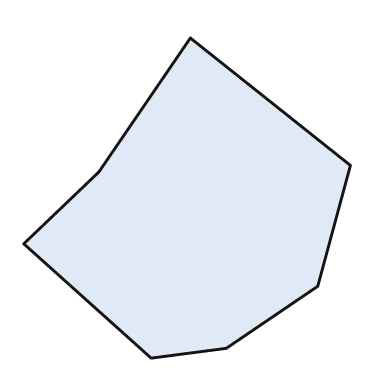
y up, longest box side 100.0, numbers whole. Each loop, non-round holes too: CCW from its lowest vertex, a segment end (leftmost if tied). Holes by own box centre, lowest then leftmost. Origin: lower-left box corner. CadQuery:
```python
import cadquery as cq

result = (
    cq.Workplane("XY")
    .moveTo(39.0, 0.0)
    .lineTo(62.0, 3.0)
    .lineTo(90.0, 22.0)
    .lineTo(100.0, 59.0)
    .lineTo(51.0, 98.0)
    .lineTo(23.0, 57.0)
    .lineTo(0.0, 35.0)
    .close()
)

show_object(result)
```